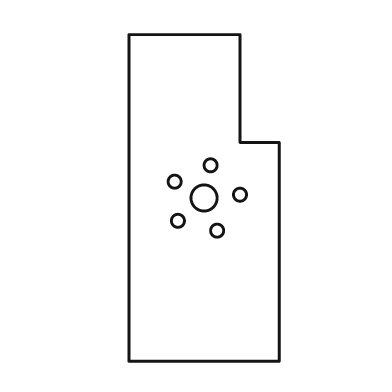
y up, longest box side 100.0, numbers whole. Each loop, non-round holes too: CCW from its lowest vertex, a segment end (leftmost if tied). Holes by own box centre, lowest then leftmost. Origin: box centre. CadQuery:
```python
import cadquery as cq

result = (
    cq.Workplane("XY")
    .moveTo(-23.0, -50.0)
    .lineTo(23.0, -50.0)
    .lineTo(23.0, 17.0)
    .lineTo(11.0, 17.0)
    .lineTo(11.0, 50.0)
    .lineTo(-23.0, 50.0)
    .close()
    .moveTo(4.0, -10.0)
    .circle(2.0)
    .moveTo(-8.0, -7.0)
    .circle(2.0)
    .moveTo(0.0, 0.0)
    .circle(4.0)
    .moveTo(11.0, 1.0)
    .circle(2.0)
    .moveTo(-9.0, 5.0)
    .circle(2.0)
    .moveTo(2.0, 10.0)
    .circle(2.0)
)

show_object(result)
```